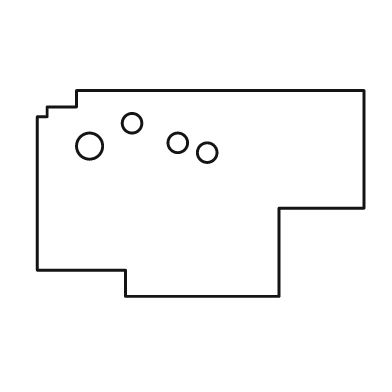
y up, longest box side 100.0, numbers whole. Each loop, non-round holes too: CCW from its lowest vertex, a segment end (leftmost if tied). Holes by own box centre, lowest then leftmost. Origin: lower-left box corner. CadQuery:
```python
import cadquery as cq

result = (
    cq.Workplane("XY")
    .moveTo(27.0, 0.0)
    .lineTo(74.0, 0.0)
    .lineTo(74.0, 27.0)
    .lineTo(100.0, 27.0)
    .lineTo(100.0, 63.0)
    .lineTo(12.0, 63.0)
    .lineTo(12.0, 58.0)
    .lineTo(3.0, 58.0)
    .lineTo(3.0, 55.0)
    .lineTo(0.0, 55.0)
    .lineTo(0.0, 8.0)
    .lineTo(27.0, 8.0)
    .close()
    .moveTo(52.0, 44.0)
    .circle(3.0)
    .moveTo(16.0, 46.0)
    .circle(4.0)
    .moveTo(43.0, 47.0)
    .circle(3.0)
    .moveTo(29.0, 53.0)
    .circle(3.0)
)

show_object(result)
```